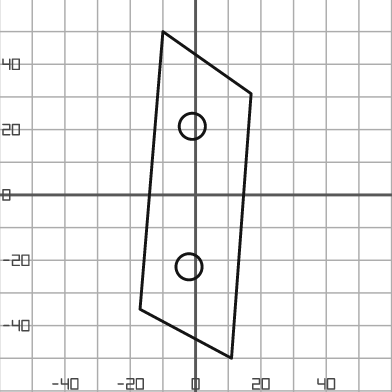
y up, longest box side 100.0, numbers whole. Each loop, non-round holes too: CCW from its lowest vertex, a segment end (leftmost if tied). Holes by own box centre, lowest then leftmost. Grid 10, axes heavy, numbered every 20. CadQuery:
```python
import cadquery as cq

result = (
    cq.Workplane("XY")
    .moveTo(11.0, -50.0)
    .lineTo(17.0, 31.0)
    .lineTo(-10.0, 50.0)
    .lineTo(-17.0, -35.0)
    .close()
    .moveTo(-2.0, -22.0)
    .circle(4.0)
    .moveTo(-1.0, 21.0)
    .circle(4.0)
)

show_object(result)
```